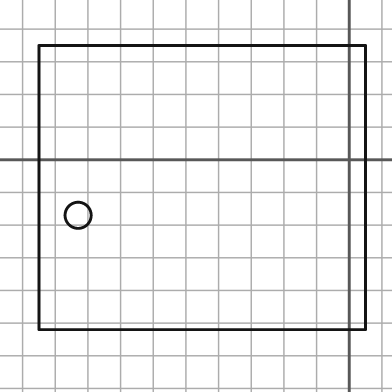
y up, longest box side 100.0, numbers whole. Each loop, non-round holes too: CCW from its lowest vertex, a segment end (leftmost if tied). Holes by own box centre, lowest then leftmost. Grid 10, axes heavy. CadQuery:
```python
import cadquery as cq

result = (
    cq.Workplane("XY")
    .moveTo(-95.0, -52.0)
    .lineTo(5.0, -52.0)
    .lineTo(5.0, 35.0)
    .lineTo(-95.0, 35.0)
    .close()
    .moveTo(-83.0, -17.0)
    .circle(4.0)
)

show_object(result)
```